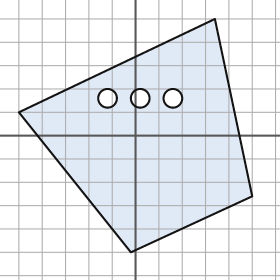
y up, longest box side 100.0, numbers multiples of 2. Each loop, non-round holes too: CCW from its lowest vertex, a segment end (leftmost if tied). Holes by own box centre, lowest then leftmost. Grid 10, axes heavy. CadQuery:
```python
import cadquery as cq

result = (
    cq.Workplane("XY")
    .moveTo(-2.0, -50.0)
    .lineTo(50.0, -26.0)
    .lineTo(34.0, 50.0)
    .lineTo(-50.0, 10.0)
    .close()
    .moveTo(-12.0, 16.0)
    .circle(4.0)
    .moveTo(2.0, 16.0)
    .circle(4.0)
    .moveTo(16.0, 16.0)
    .circle(4.0)
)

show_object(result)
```